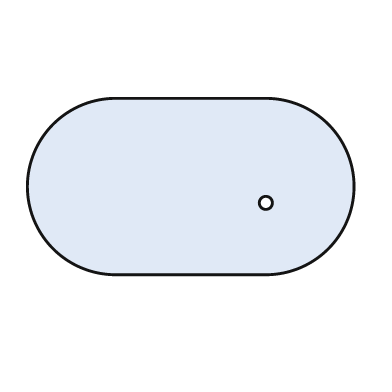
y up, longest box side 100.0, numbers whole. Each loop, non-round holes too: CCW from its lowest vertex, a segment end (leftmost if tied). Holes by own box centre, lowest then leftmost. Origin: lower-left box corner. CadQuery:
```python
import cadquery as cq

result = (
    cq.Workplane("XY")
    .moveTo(27.0, 0.0)
    .lineTo(73.0, 0.0)
    .threePointArc((100.0, 27.0), (73.0, 54.0))
    .lineTo(27.0, 54.0)
    .threePointArc((0.0, 27.0), (27.0, 0.0))
    .close()
    .moveTo(73.0, 22.0)
    .circle(2.0)
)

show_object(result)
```